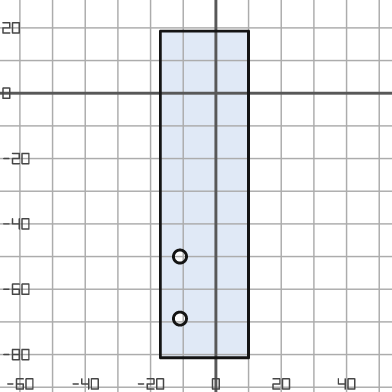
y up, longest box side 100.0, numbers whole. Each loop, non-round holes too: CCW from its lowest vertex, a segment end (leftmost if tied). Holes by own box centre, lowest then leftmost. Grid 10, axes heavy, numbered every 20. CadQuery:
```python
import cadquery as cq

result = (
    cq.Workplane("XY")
    .moveTo(-17.0, -81.0)
    .lineTo(10.0, -81.0)
    .lineTo(10.0, 19.0)
    .lineTo(-17.0, 19.0)
    .close()
    .moveTo(-11.0, -69.0)
    .circle(2.0)
    .moveTo(-11.0, -50.0)
    .circle(2.0)
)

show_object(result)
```